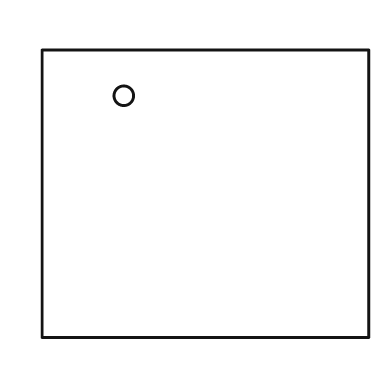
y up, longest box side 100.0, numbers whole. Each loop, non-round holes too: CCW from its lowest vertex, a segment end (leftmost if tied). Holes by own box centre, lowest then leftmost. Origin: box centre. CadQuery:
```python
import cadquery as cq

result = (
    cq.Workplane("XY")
    .moveTo(-50.0, -44.0)
    .lineTo(50.0, -44.0)
    .lineTo(50.0, 44.0)
    .lineTo(-50.0, 44.0)
    .close()
    .moveTo(-25.0, 30.0)
    .circle(3.0)
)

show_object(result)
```